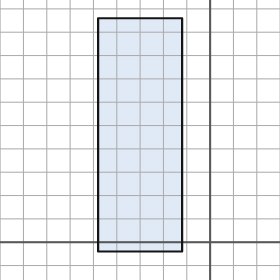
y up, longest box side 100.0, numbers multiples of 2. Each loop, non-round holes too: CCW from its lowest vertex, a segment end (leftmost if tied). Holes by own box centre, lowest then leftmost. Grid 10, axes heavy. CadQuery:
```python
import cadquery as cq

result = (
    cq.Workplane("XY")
    .moveTo(-48.0, -4.0)
    .lineTo(-12.0, -4.0)
    .lineTo(-12.0, 96.0)
    .lineTo(-48.0, 96.0)
    .close()
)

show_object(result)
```